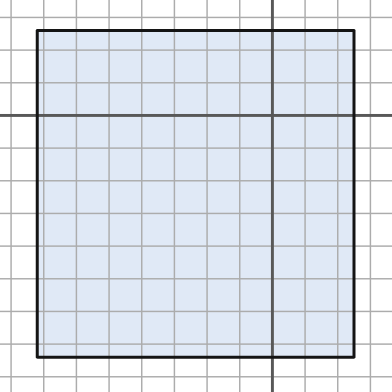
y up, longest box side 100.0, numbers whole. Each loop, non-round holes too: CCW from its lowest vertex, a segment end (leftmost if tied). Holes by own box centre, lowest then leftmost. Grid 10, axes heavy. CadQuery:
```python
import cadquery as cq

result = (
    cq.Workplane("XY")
    .moveTo(-72.0, -74.0)
    .lineTo(25.0, -74.0)
    .lineTo(25.0, 26.0)
    .lineTo(-72.0, 26.0)
    .close()
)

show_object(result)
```